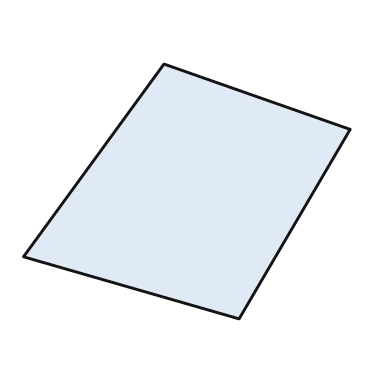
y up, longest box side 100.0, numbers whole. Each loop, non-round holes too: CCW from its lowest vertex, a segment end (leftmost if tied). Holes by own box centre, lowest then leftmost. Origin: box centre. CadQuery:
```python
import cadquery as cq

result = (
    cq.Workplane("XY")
    .moveTo(16.0, -39.0)
    .lineTo(50.0, 19.0)
    .lineTo(-7.0, 39.0)
    .lineTo(-50.0, -20.0)
    .close()
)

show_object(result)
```